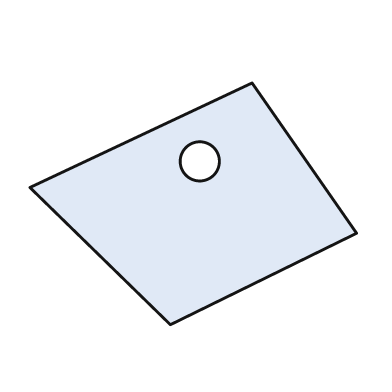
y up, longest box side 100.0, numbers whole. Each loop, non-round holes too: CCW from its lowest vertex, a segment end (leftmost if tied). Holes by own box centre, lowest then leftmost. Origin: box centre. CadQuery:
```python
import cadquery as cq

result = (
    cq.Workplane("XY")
    .moveTo(-7.0, -37.0)
    .lineTo(50.0, -9.0)
    .lineTo(18.0, 37.0)
    .lineTo(-50.0, 5.0)
    .close()
    .moveTo(2.0, 13.0)
    .circle(6.0)
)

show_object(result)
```